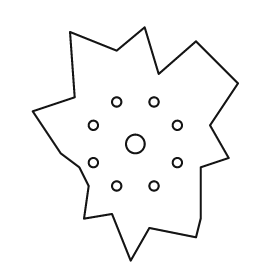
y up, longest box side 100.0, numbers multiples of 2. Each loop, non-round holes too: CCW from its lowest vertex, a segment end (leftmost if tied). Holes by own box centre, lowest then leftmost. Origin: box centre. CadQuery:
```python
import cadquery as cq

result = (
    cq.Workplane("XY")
    .moveTo(-2.0, -50.0)
    .lineTo(6.0, -36.0)
    .lineTo(26.0, -40.0)
    .lineTo(28.0, -32.0)
    .lineTo(28.0, -10.0)
    .lineTo(40.0, -6.0)
    .lineTo(32.0, 8.0)
    .lineTo(44.0, 26.0)
    .lineTo(26.0, 44.0)
    .lineTo(10.0, 30.0)
    .lineTo(4.0, 50.0)
    .lineTo(-8.0, 40.0)
    .lineTo(-28.0, 48.0)
    .lineTo(-26.0, 20.0)
    .lineTo(-44.0, 14.0)
    .lineTo(-32.0, -4.0)
    .lineTo(-24.0, -10.0)
    .lineTo(-20.0, -18.0)
    .lineTo(-22.0, -32.0)
    .lineTo(-10.0, -30.0)
    .close()
    .moveTo(-8.0, -18.0)
    .circle(2.0)
    .moveTo(8.0, -18.0)
    .circle(2.0)
    .moveTo(-18.0, -8.0)
    .circle(2.0)
    .moveTo(18.0, -8.0)
    .circle(2.0)
    .moveTo(0.0, 0.0)
    .circle(4.0)
    .moveTo(-18.0, 8.0)
    .circle(2.0)
    .moveTo(18.0, 8.0)
    .circle(2.0)
    .moveTo(-8.0, 18.0)
    .circle(2.0)
    .moveTo(8.0, 18.0)
    .circle(2.0)
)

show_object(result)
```